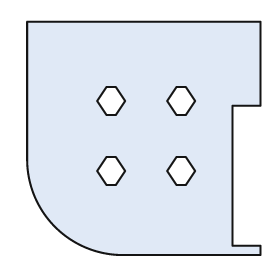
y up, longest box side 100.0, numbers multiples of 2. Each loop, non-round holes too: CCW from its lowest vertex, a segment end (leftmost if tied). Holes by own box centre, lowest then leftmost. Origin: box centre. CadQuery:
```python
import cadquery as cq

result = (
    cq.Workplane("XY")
    .moveTo(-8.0, -50.0)
    .lineTo(50.0, -50.0)
    .lineTo(50.0, -46.0)
    .lineTo(38.0, -46.0)
    .lineTo(38.0, 14.0)
    .lineTo(50.0, 14.0)
    .lineTo(50.0, 50.0)
    .lineTo(-50.0, 50.0)
    .lineTo(-50.0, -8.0)
    .threePointArc((-38.0, -38.0), (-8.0, -50.0))
    .close()
    .moveTo(-16.0, -20.0)
    .lineTo(-12.0, -20.0)
    .lineTo(-8.0, -14.0)
    .lineTo(-12.0, -8.0)
    .lineTo(-16.0, -8.0)
    .lineTo(-20.0, -14.0)
    .close()
    .moveTo(14.0, -20.0)
    .lineTo(18.0, -20.0)
    .lineTo(22.0, -14.0)
    .lineTo(18.0, -8.0)
    .lineTo(14.0, -8.0)
    .lineTo(10.0, -14.0)
    .close()
    .moveTo(-16.0, 10.0)
    .lineTo(-12.0, 10.0)
    .lineTo(-8.0, 16.0)
    .lineTo(-12.0, 22.0)
    .lineTo(-16.0, 22.0)
    .lineTo(-20.0, 16.0)
    .close()
    .moveTo(14.0, 10.0)
    .lineTo(18.0, 10.0)
    .lineTo(22.0, 16.0)
    .lineTo(18.0, 22.0)
    .lineTo(14.0, 22.0)
    .lineTo(10.0, 16.0)
    .close()
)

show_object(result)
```